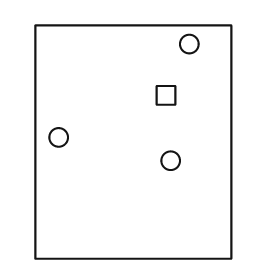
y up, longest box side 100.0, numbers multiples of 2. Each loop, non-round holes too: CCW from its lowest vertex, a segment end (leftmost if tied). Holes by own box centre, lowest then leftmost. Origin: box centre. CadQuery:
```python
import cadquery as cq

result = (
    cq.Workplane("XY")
    .moveTo(-42.0, -50.0)
    .lineTo(42.0, -50.0)
    .lineTo(42.0, 50.0)
    .lineTo(-42.0, 50.0)
    .close()
    .moveTo(16.0, -8.0)
    .circle(4.0)
    .moveTo(-32.0, 2.0)
    .circle(4.0)
    .moveTo(10.0, 16.0)
    .lineTo(18.0, 16.0)
    .lineTo(18.0, 24.0)
    .lineTo(10.0, 24.0)
    .close()
    .moveTo(24.0, 42.0)
    .circle(4.0)
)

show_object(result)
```